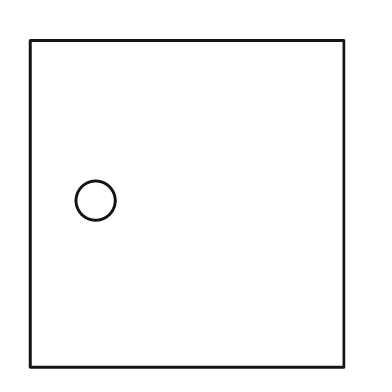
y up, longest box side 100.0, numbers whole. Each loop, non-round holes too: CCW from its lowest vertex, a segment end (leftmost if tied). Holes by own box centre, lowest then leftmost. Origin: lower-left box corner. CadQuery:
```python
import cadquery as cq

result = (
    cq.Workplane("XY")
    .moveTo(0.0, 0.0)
    .lineTo(96.0, 0.0)
    .lineTo(96.0, 100.0)
    .lineTo(0.0, 100.0)
    .close()
    .moveTo(20.0, 51.0)
    .circle(6.0)
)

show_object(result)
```